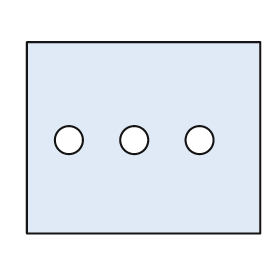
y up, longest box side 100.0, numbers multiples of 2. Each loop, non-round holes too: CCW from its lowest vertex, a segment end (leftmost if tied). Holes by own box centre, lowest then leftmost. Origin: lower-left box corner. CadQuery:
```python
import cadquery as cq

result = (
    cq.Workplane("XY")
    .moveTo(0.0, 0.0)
    .lineTo(100.0, 0.0)
    .lineTo(100.0, 82.0)
    .lineTo(0.0, 82.0)
    .close()
    .moveTo(18.0, 40.0)
    .circle(6.0)
    .moveTo(46.0, 40.0)
    .circle(6.0)
    .moveTo(74.0, 40.0)
    .circle(6.0)
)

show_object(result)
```